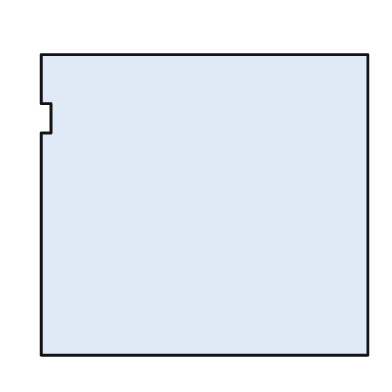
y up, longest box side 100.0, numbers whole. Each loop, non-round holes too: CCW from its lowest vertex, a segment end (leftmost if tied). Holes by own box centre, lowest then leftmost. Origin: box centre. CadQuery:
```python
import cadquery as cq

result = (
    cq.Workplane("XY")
    .moveTo(-50.0, -46.0)
    .lineTo(50.0, -46.0)
    .lineTo(50.0, 46.0)
    .lineTo(-50.0, 46.0)
    .lineTo(-50.0, 31.0)
    .lineTo(-47.0, 31.0)
    .lineTo(-47.0, 22.0)
    .lineTo(-50.0, 22.0)
    .close()
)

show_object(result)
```